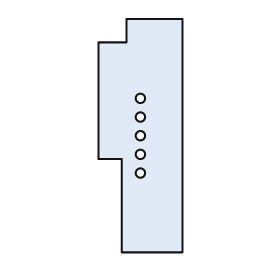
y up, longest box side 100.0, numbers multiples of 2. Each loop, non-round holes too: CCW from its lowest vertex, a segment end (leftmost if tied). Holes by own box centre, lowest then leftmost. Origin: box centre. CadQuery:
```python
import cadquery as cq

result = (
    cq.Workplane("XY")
    .moveTo(-8.0, -50.0)
    .lineTo(18.0, -50.0)
    .lineTo(18.0, 50.0)
    .lineTo(-6.0, 50.0)
    .lineTo(-6.0, 40.0)
    .lineTo(-18.0, 40.0)
    .lineTo(-18.0, -10.0)
    .lineTo(-8.0, -10.0)
    .close()
    .moveTo(0.0, -16.0)
    .circle(2.0)
    .moveTo(0.0, -8.0)
    .circle(2.0)
    .moveTo(0.0, 0.0)
    .circle(2.0)
    .moveTo(0.0, 8.0)
    .circle(2.0)
    .moveTo(0.0, 16.0)
    .circle(2.0)
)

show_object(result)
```